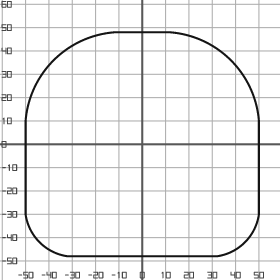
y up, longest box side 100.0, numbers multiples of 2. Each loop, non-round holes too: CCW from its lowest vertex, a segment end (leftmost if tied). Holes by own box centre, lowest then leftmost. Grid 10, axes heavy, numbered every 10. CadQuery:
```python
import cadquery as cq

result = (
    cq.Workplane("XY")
    .moveTo(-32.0, -48.0)
    .lineTo(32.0, -48.0)
    .threePointArc((44.0, -42.0), (50.0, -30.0))
    .lineTo(50.0, 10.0)
    .threePointArc((38.0, 36.0), (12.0, 48.0))
    .lineTo(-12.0, 48.0)
    .threePointArc((-38.0, 36.0), (-50.0, 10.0))
    .lineTo(-50.0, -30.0)
    .threePointArc((-44.0, -42.0), (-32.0, -48.0))
    .close()
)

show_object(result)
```